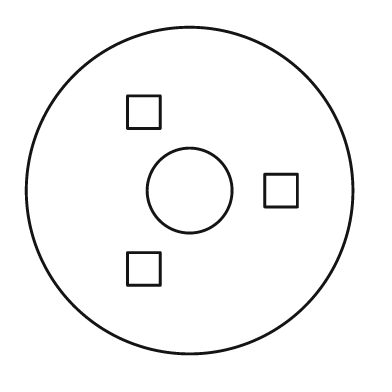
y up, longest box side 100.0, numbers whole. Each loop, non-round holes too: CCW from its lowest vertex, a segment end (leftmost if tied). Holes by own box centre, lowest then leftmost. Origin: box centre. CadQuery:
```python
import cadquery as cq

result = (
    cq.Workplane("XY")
    .moveTo(0.0, 0.0)
    .circle(50.0)
    .moveTo(-19.0, -29.0)
    .lineTo(-9.0, -29.0)
    .lineTo(-9.0, -19.0)
    .lineTo(-19.0, -19.0)
    .close()
    .moveTo(0.0, 0.0)
    .circle(13.0)
    .moveTo(23.0, -5.0)
    .lineTo(33.0, -5.0)
    .lineTo(33.0, 5.0)
    .lineTo(23.0, 5.0)
    .close()
    .moveTo(-19.0, 19.0)
    .lineTo(-9.0, 19.0)
    .lineTo(-9.0, 29.0)
    .lineTo(-19.0, 29.0)
    .close()
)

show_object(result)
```